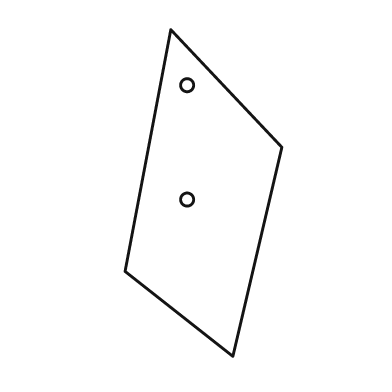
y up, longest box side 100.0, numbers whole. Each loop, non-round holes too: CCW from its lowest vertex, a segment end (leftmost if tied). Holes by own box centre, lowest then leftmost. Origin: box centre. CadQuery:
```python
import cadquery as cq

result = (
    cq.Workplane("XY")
    .moveTo(9.0, -50.0)
    .lineTo(24.0, 14.0)
    .lineTo(-10.0, 50.0)
    .lineTo(-24.0, -24.0)
    .close()
    .moveTo(-5.0, -2.0)
    .circle(2.0)
    .moveTo(-5.0, 33.0)
    .circle(2.0)
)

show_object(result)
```